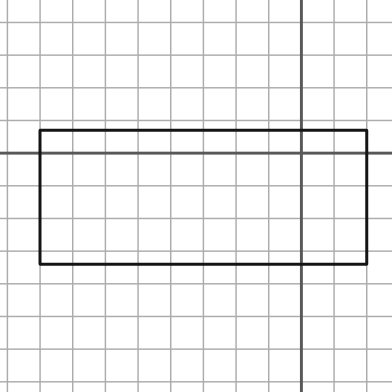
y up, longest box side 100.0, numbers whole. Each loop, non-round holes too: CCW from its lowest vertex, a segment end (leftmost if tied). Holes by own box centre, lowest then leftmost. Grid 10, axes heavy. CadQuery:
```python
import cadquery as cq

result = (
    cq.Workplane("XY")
    .moveTo(-80.0, -34.0)
    .lineTo(20.0, -34.0)
    .lineTo(20.0, 7.0)
    .lineTo(-80.0, 7.0)
    .close()
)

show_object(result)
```